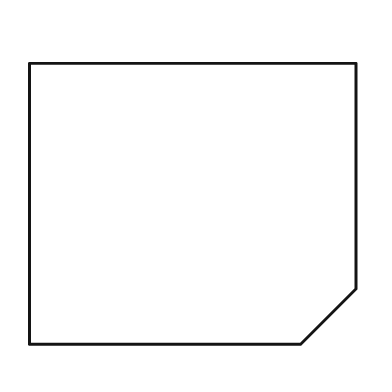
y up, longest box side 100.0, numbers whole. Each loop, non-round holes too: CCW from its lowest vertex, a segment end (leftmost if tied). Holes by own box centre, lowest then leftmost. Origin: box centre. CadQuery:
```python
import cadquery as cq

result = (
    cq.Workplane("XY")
    .moveTo(-50.0, -43.0)
    .lineTo(33.0, -43.0)
    .lineTo(50.0, -26.0)
    .lineTo(50.0, 43.0)
    .lineTo(-50.0, 43.0)
    .close()
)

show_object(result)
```